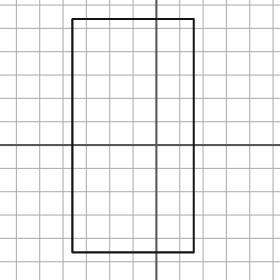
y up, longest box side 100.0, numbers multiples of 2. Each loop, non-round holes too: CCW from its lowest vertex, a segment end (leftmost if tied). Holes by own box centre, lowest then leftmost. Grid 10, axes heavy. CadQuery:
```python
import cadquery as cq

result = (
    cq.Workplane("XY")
    .moveTo(-36.0, -46.0)
    .lineTo(16.0, -46.0)
    .lineTo(16.0, 54.0)
    .lineTo(-36.0, 54.0)
    .close()
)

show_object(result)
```